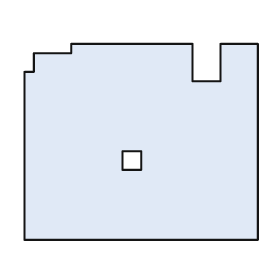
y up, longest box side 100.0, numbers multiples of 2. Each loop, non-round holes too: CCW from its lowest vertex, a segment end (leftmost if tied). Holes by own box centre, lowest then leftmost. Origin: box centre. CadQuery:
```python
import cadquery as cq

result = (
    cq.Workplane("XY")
    .moveTo(-50.0, -42.0)
    .lineTo(50.0, -42.0)
    .lineTo(50.0, 42.0)
    .lineTo(34.0, 42.0)
    .lineTo(34.0, 26.0)
    .lineTo(22.0, 26.0)
    .lineTo(22.0, 42.0)
    .lineTo(-30.0, 42.0)
    .lineTo(-30.0, 38.0)
    .lineTo(-46.0, 38.0)
    .lineTo(-46.0, 30.0)
    .lineTo(-50.0, 30.0)
    .close()
    .moveTo(-8.0, -12.0)
    .lineTo(0.0, -12.0)
    .lineTo(0.0, -4.0)
    .lineTo(-8.0, -4.0)
    .close()
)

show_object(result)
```